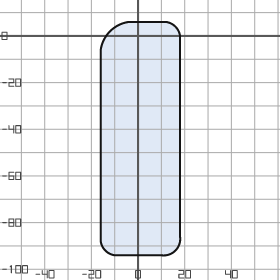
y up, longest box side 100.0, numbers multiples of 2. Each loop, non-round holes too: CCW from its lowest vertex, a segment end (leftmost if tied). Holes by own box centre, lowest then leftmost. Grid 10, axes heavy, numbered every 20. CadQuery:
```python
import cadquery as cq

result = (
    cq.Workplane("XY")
    .moveTo(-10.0, -94.0)
    .lineTo(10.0, -94.0)
    .threePointArc((16.0, -92.0), (18.0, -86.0))
    .lineTo(18.0, 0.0)
    .threePointArc((16.0, 4.0), (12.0, 6.0))
    .lineTo(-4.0, 6.0)
    .threePointArc((-12.0, 2.0), (-16.0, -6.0))
    .lineTo(-16.0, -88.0)
    .threePointArc((-14.0, -92.0), (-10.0, -94.0))
    .close()
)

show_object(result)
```